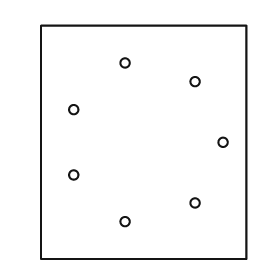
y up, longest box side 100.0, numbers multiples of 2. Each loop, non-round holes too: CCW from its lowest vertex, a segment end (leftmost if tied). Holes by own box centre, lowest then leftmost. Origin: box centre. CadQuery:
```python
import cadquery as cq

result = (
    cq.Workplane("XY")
    .moveTo(-44.0, -50.0)
    .lineTo(44.0, -50.0)
    .lineTo(44.0, 50.0)
    .lineTo(-44.0, 50.0)
    .close()
    .moveTo(-8.0, -34.0)
    .circle(2.0)
    .moveTo(22.0, -26.0)
    .circle(2.0)
    .moveTo(-30.0, -14.0)
    .circle(2.0)
    .moveTo(34.0, 0.0)
    .circle(2.0)
    .moveTo(-30.0, 14.0)
    .circle(2.0)
    .moveTo(22.0, 26.0)
    .circle(2.0)
    .moveTo(-8.0, 34.0)
    .circle(2.0)
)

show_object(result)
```